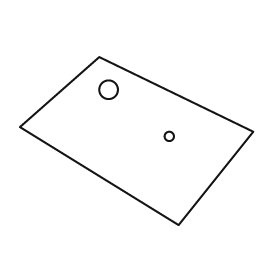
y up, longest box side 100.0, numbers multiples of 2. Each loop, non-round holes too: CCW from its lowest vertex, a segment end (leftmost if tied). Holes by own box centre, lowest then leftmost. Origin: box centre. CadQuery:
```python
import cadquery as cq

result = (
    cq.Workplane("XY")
    .moveTo(18.0, -36.0)
    .lineTo(50.0, 4.0)
    .lineTo(-16.0, 36.0)
    .lineTo(-50.0, 6.0)
    .close()
    .moveTo(14.0, 2.0)
    .circle(2.0)
    .moveTo(-12.0, 22.0)
    .circle(4.0)
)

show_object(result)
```